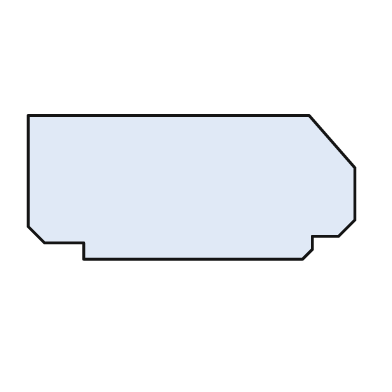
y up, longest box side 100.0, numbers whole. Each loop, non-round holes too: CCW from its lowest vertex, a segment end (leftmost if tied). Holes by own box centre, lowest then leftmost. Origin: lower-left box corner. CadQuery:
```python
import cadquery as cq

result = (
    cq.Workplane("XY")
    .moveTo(17.0, 0.0)
    .lineTo(84.0, 0.0)
    .lineTo(87.0, 3.0)
    .lineTo(87.0, 7.0)
    .lineTo(95.0, 7.0)
    .lineTo(100.0, 12.0)
    .lineTo(100.0, 28.0)
    .lineTo(86.0, 44.0)
    .lineTo(0.0, 44.0)
    .lineTo(0.0, 10.0)
    .lineTo(5.0, 5.0)
    .lineTo(17.0, 5.0)
    .close()
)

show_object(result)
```